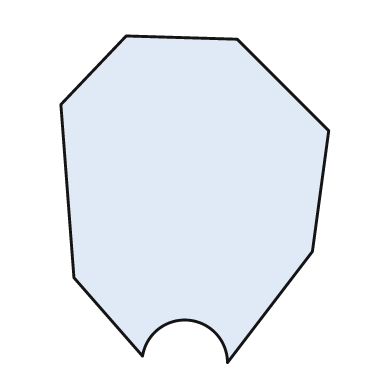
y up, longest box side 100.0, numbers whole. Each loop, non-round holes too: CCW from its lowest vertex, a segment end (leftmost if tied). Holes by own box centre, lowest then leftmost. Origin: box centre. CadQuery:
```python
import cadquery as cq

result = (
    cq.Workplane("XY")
    .moveTo(10.0, -50.0)
    .lineTo(36.0, -16.0)
    .lineTo(41.0, 21.0)
    .lineTo(13.0, 49.0)
    .lineTo(-21.0, 50.0)
    .lineTo(-41.0, 29.0)
    .lineTo(-37.0, -24.0)
    .lineTo(-16.0, -48.0)
    .threePointArc((-2.0, -37.0), (10.0, -50.0))
    .close()
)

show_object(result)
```